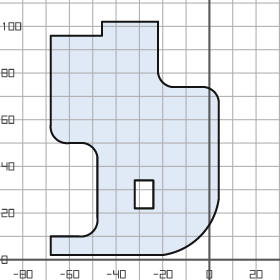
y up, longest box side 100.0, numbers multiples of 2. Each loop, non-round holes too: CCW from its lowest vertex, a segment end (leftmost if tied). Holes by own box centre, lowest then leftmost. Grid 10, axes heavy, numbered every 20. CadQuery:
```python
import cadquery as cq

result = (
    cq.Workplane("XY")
    .moveTo(-68.0, 2.0)
    .lineTo(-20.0, 2.0)
    .threePointArc((-4.0, 10.0), (4.0, 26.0))
    .lineTo(4.0, 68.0)
    .threePointArc((2.0, 72.0), (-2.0, 74.0))
    .lineTo(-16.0, 74.0)
    .threePointArc((-20.0, 76.0), (-22.0, 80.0))
    .lineTo(-22.0, 102.0)
    .lineTo(-46.0, 102.0)
    .lineTo(-46.0, 96.0)
    .lineTo(-68.0, 96.0)
    .lineTo(-68.0, 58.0)
    .threePointArc((-66.0, 52.0), (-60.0, 50.0))
    .lineTo(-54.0, 50.0)
    .threePointArc((-50.0, 48.0), (-48.0, 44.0))
    .lineTo(-48.0, 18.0)
    .threePointArc((-50.0, 12.0), (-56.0, 10.0))
    .lineTo(-68.0, 10.0)
    .close()
    .moveTo(-32.0, 22.0)
    .lineTo(-24.0, 22.0)
    .lineTo(-24.0, 34.0)
    .lineTo(-32.0, 34.0)
    .close()
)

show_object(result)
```